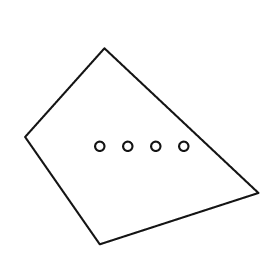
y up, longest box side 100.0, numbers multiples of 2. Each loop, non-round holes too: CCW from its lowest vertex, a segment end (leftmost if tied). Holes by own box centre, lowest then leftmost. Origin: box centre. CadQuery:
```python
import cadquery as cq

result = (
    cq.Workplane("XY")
    .moveTo(-18.0, -42.0)
    .lineTo(50.0, -20.0)
    .lineTo(-16.0, 42.0)
    .lineTo(-50.0, 4.0)
    .close()
    .moveTo(-18.0, 0.0)
    .circle(2.0)
    .moveTo(-6.0, 0.0)
    .circle(2.0)
    .moveTo(6.0, 0.0)
    .circle(2.0)
    .moveTo(18.0, 0.0)
    .circle(2.0)
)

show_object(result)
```